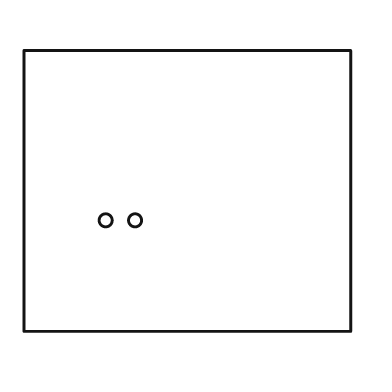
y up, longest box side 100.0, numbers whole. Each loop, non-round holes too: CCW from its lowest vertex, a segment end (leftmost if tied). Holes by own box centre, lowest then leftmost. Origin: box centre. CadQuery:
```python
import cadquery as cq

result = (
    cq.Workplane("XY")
    .moveTo(-50.0, -43.0)
    .lineTo(50.0, -43.0)
    .lineTo(50.0, 43.0)
    .lineTo(-50.0, 43.0)
    .close()
    .moveTo(-25.0, -9.0)
    .circle(2.0)
    .moveTo(-16.0, -9.0)
    .circle(2.0)
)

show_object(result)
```